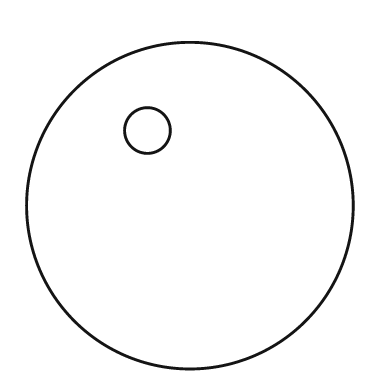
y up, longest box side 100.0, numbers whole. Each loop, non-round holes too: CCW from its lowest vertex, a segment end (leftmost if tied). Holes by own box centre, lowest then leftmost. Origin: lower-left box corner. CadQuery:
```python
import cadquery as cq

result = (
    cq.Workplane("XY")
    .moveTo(50.0, 50.0)
    .circle(50.0)
    .moveTo(37.0, 73.0)
    .circle(7.0)
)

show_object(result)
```